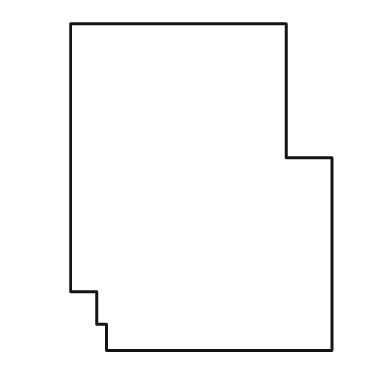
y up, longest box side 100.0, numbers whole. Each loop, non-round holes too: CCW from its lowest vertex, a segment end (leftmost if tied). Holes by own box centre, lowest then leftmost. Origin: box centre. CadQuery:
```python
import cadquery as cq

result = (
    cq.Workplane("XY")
    .moveTo(-29.0, -50.0)
    .lineTo(40.0, -50.0)
    .lineTo(40.0, 9.0)
    .lineTo(26.0, 9.0)
    .lineTo(26.0, 50.0)
    .lineTo(-40.0, 50.0)
    .lineTo(-40.0, -32.0)
    .lineTo(-32.0, -32.0)
    .lineTo(-32.0, -42.0)
    .lineTo(-29.0, -42.0)
    .close()
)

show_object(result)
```